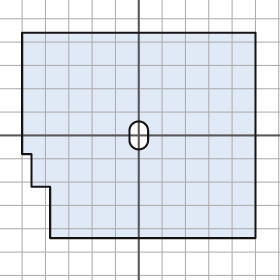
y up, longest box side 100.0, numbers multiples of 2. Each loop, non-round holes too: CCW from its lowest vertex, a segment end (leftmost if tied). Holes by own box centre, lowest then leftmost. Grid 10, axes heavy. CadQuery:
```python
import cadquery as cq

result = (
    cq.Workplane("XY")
    .moveTo(-38.0, -44.0)
    .lineTo(50.0, -44.0)
    .lineTo(50.0, 44.0)
    .lineTo(-50.0, 44.0)
    .lineTo(-50.0, -8.0)
    .lineTo(-46.0, -8.0)
    .lineTo(-46.0, -22.0)
    .lineTo(-38.0, -22.0)
    .close()
    .moveTo(-4.0, -2.0)
    .threePointArc((0.0, -6.0), (4.0, -2.0))
    .lineTo(4.0, 2.0)
    .threePointArc((0.0, 6.0), (-4.0, 2.0))
    .close()
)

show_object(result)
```